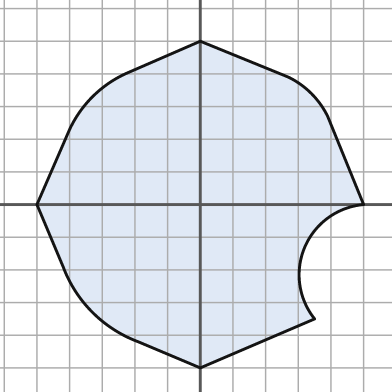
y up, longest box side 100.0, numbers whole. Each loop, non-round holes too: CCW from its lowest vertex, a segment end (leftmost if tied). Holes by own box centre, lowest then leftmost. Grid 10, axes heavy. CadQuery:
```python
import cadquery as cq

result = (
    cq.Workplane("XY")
    .moveTo(0.0, -50.0)
    .lineTo(35.0, -35.0)
    .threePointArc((32.0, -13.0), (50.0, 0.0))
    .lineTo(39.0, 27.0)
    .threePointArc((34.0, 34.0), (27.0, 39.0))
    .lineTo(0.0, 50.0)
    .lineTo(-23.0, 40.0)
    .threePointArc((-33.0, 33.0), (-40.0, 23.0))
    .lineTo(-50.0, 0.0)
    .lineTo(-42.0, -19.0)
    .threePointArc((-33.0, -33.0), (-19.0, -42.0))
    .close()
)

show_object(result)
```